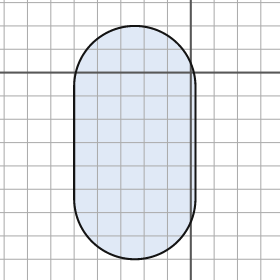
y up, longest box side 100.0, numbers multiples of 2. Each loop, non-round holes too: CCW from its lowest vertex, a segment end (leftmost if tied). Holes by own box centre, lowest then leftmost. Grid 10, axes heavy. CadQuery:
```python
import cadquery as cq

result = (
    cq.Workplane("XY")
    .moveTo(-50.0, -54.0)
    .threePointArc((-24.0, -80.0), (2.0, -54.0))
    .lineTo(2.0, -6.0)
    .threePointArc((-24.0, 20.0), (-50.0, -6.0))
    .close()
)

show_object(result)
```